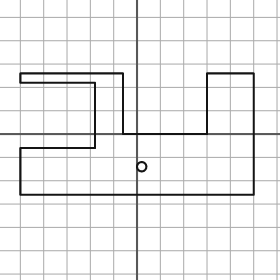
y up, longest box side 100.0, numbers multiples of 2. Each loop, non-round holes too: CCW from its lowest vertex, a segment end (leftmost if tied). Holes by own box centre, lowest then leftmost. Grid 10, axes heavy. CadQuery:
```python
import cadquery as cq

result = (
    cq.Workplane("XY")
    .moveTo(-50.0, -26.0)
    .lineTo(50.0, -26.0)
    .lineTo(50.0, 26.0)
    .lineTo(30.0, 26.0)
    .lineTo(30.0, 0.0)
    .lineTo(-6.0, 0.0)
    .lineTo(-6.0, 26.0)
    .lineTo(-50.0, 26.0)
    .lineTo(-50.0, 22.0)
    .lineTo(-18.0, 22.0)
    .lineTo(-18.0, -6.0)
    .lineTo(-50.0, -6.0)
    .close()
    .moveTo(2.0, -14.0)
    .circle(2.0)
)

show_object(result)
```